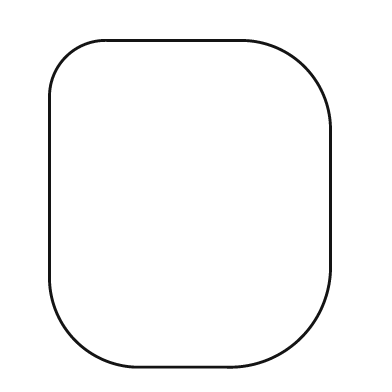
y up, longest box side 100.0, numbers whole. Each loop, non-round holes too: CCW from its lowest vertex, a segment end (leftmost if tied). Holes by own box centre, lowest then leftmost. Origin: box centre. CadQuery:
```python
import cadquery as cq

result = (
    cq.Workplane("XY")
    .moveTo(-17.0, -50.0)
    .lineTo(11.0, -50.0)
    .threePointArc((34.0, -41.0), (43.0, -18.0))
    .lineTo(43.0, 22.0)
    .threePointArc((35.0, 42.0), (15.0, 50.0))
    .lineTo(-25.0, 50.0)
    .threePointArc((-38.0, 45.0), (-43.0, 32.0))
    .lineTo(-43.0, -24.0)
    .threePointArc((-35.0, -42.0), (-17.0, -50.0))
    .close()
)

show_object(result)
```